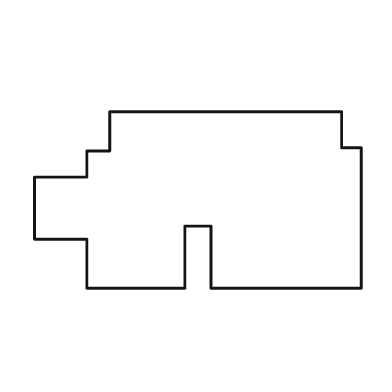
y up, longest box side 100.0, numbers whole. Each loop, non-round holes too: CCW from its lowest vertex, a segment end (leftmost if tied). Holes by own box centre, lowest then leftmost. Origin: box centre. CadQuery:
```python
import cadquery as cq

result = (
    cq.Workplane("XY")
    .moveTo(-34.0, -27.0)
    .lineTo(-4.0, -27.0)
    .lineTo(-4.0, -8.0)
    .lineTo(4.0, -8.0)
    .lineTo(4.0, -27.0)
    .lineTo(50.0, -27.0)
    .lineTo(50.0, 16.0)
    .lineTo(44.0, 16.0)
    .lineTo(44.0, 27.0)
    .lineTo(-27.0, 27.0)
    .lineTo(-27.0, 15.0)
    .lineTo(-34.0, 15.0)
    .lineTo(-34.0, 7.0)
    .lineTo(-50.0, 7.0)
    .lineTo(-50.0, -12.0)
    .lineTo(-34.0, -12.0)
    .close()
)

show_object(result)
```